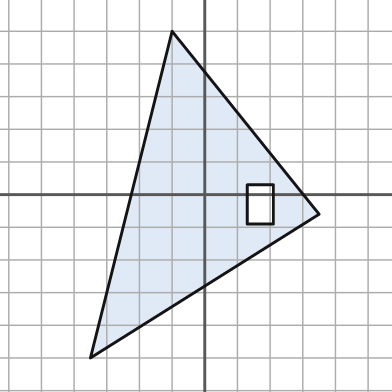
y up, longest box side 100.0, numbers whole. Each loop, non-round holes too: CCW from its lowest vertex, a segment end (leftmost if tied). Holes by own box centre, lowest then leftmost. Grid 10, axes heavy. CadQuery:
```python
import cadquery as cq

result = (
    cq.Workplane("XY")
    .moveTo(-35.0, -50.0)
    .lineTo(35.0, -6.0)
    .lineTo(-10.0, 50.0)
    .close()
    .moveTo(13.0, -9.0)
    .lineTo(21.0, -9.0)
    .lineTo(21.0, 3.0)
    .lineTo(13.0, 3.0)
    .close()
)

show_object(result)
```